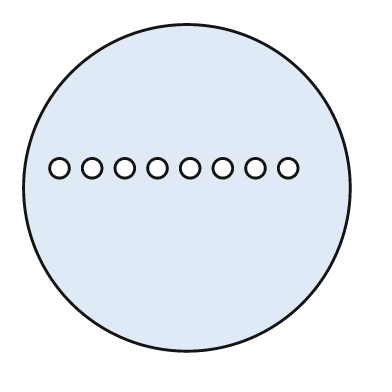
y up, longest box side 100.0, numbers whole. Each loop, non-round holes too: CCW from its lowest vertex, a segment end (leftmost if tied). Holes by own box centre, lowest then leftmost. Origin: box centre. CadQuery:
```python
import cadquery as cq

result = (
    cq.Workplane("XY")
    .moveTo(0.0, 0.0)
    .circle(50.0)
    .moveTo(-39.0, 6.0)
    .circle(3.0)
    .moveTo(-29.0, 6.0)
    .circle(3.0)
    .moveTo(-19.0, 6.0)
    .circle(3.0)
    .moveTo(-9.0, 6.0)
    .circle(3.0)
    .moveTo(1.0, 6.0)
    .circle(3.0)
    .moveTo(11.0, 6.0)
    .circle(3.0)
    .moveTo(21.0, 6.0)
    .circle(3.0)
    .moveTo(31.0, 6.0)
    .circle(3.0)
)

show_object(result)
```